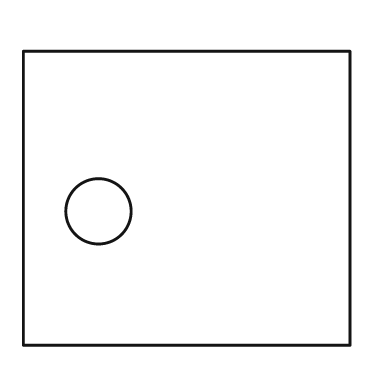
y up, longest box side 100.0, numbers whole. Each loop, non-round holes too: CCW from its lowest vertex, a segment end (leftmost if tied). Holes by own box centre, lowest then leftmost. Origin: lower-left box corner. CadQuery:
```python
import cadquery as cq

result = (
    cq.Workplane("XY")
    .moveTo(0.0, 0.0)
    .lineTo(100.0, 0.0)
    .lineTo(100.0, 90.0)
    .lineTo(0.0, 90.0)
    .close()
    .moveTo(23.0, 41.0)
    .circle(10.0)
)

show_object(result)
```